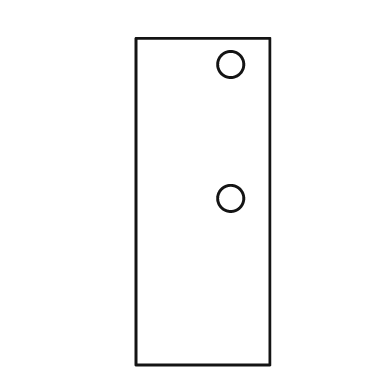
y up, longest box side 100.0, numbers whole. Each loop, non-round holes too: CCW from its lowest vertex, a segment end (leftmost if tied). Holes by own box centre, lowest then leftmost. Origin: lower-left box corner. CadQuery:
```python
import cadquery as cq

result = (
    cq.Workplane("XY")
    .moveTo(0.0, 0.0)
    .lineTo(41.0, 0.0)
    .lineTo(41.0, 100.0)
    .lineTo(0.0, 100.0)
    .close()
    .moveTo(29.0, 51.0)
    .circle(4.0)
    .moveTo(29.0, 92.0)
    .circle(4.0)
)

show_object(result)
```